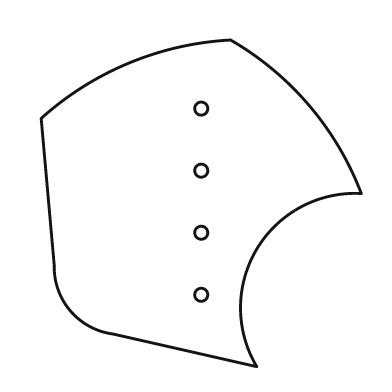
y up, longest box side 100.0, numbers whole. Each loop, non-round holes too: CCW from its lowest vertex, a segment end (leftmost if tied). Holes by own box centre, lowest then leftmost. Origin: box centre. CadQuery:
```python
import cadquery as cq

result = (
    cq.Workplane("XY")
    .moveTo(17.0, -50.0)
    .threePointArc((17.0, -14.0), (49.0, 3.0))
    .threePointArc((33.0, 30.0), (9.0, 50.0))
    .threePointArc((-22.0, 43.0), (-49.0, 26.0))
    .lineTo(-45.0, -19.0)
    .threePointArc((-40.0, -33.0), (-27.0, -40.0))
    .close()
    .moveTo(0.0, -28.0)
    .circle(2.0)
    .moveTo(0.0, -9.0)
    .circle(2.0)
    .moveTo(0.0, 10.0)
    .circle(2.0)
    .moveTo(0.0, 29.0)
    .circle(2.0)
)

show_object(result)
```